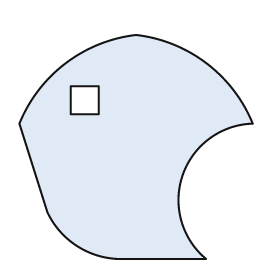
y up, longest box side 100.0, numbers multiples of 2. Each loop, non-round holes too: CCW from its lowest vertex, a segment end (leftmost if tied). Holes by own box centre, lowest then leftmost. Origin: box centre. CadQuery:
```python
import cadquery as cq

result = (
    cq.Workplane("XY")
    .moveTo(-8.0, -48.0)
    .lineTo(30.0, -48.0)
    .threePointArc((20.0, -12.0), (50.0, 10.0))
    .threePointArc((30.0, 36.0), (0.0, 48.0))
    .threePointArc((-30.0, 36.0), (-50.0, 10.0))
    .lineTo(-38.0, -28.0)
    .threePointArc((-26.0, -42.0), (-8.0, -48.0))
    .close()
    .moveTo(-28.0, 14.0)
    .lineTo(-16.0, 14.0)
    .lineTo(-16.0, 26.0)
    .lineTo(-28.0, 26.0)
    .close()
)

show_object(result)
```